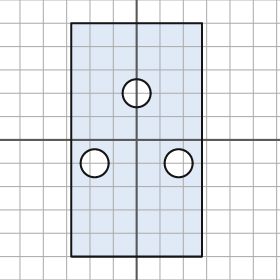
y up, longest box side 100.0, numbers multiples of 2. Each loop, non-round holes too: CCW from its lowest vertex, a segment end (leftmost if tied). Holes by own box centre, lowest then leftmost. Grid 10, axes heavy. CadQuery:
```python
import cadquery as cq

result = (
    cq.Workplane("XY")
    .moveTo(-28.0, -50.0)
    .lineTo(28.0, -50.0)
    .lineTo(28.0, 50.0)
    .lineTo(-28.0, 50.0)
    .close()
    .moveTo(-18.0, -10.0)
    .circle(6.0)
    .moveTo(18.0, -10.0)
    .circle(6.0)
    .moveTo(0.0, 20.0)
    .circle(6.0)
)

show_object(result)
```